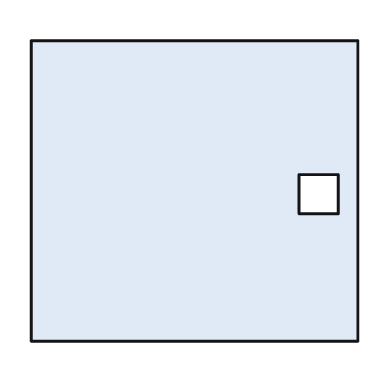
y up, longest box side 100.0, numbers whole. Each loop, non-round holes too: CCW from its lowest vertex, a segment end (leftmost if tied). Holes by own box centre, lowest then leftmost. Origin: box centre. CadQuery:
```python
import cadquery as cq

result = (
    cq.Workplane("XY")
    .moveTo(-50.0, -46.0)
    .lineTo(50.0, -46.0)
    .lineTo(50.0, 46.0)
    .lineTo(-50.0, 46.0)
    .close()
    .moveTo(32.0, -7.0)
    .lineTo(44.0, -7.0)
    .lineTo(44.0, 5.0)
    .lineTo(32.0, 5.0)
    .close()
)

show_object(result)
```